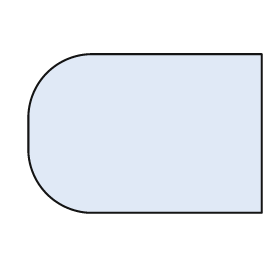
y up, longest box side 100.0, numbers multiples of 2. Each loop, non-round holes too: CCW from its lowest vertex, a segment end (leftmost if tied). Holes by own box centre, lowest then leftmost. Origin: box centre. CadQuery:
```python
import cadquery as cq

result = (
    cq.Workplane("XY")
    .moveTo(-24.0, -34.0)
    .lineTo(50.0, -34.0)
    .lineTo(50.0, 34.0)
    .lineTo(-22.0, 34.0)
    .threePointArc((-42.0, 26.0), (-50.0, 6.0))
    .lineTo(-50.0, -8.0)
    .threePointArc((-42.0, -26.0), (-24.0, -34.0))
    .close()
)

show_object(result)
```